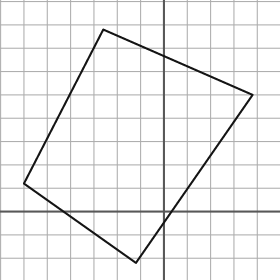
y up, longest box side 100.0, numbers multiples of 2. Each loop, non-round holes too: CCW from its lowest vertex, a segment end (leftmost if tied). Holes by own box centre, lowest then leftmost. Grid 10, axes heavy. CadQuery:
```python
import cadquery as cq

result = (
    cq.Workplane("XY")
    .moveTo(-12.0, -22.0)
    .lineTo(38.0, 50.0)
    .lineTo(-26.0, 78.0)
    .lineTo(-60.0, 12.0)
    .close()
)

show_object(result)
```